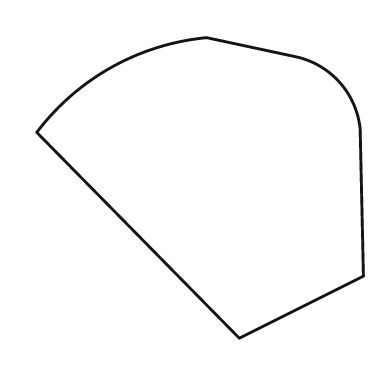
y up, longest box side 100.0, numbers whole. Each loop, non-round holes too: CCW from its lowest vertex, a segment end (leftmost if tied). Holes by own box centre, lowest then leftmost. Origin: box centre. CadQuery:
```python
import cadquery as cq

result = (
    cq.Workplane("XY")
    .moveTo(12.0, -46.0)
    .lineTo(50.0, -27.0)
    .lineTo(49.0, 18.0)
    .threePointArc((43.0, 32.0), (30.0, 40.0))
    .lineTo(2.0, 46.0)
    .threePointArc((-27.0, 37.0), (-50.0, 17.0))
    .close()
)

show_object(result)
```